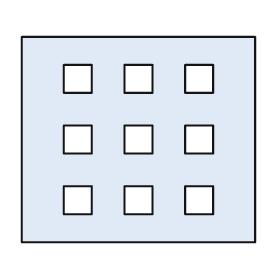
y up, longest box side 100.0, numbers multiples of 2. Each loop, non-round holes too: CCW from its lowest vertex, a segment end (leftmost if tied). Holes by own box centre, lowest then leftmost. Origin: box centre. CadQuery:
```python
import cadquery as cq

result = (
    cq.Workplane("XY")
    .moveTo(-50.0, -44.0)
    .lineTo(50.0, -44.0)
    .lineTo(50.0, 44.0)
    .lineTo(-50.0, 44.0)
    .close()
    .moveTo(-32.0, -32.0)
    .lineTo(-20.0, -32.0)
    .lineTo(-20.0, -20.0)
    .lineTo(-32.0, -20.0)
    .close()
    .moveTo(-6.0, -32.0)
    .lineTo(6.0, -32.0)
    .lineTo(6.0, -20.0)
    .lineTo(-6.0, -20.0)
    .close()
    .moveTo(20.0, -32.0)
    .lineTo(32.0, -32.0)
    .lineTo(32.0, -20.0)
    .lineTo(20.0, -20.0)
    .close()
    .moveTo(-32.0, -6.0)
    .lineTo(-20.0, -6.0)
    .lineTo(-20.0, 6.0)
    .lineTo(-32.0, 6.0)
    .close()
    .moveTo(-6.0, -6.0)
    .lineTo(6.0, -6.0)
    .lineTo(6.0, 6.0)
    .lineTo(-6.0, 6.0)
    .close()
    .moveTo(20.0, -6.0)
    .lineTo(32.0, -6.0)
    .lineTo(32.0, 6.0)
    .lineTo(20.0, 6.0)
    .close()
    .moveTo(-32.0, 20.0)
    .lineTo(-20.0, 20.0)
    .lineTo(-20.0, 32.0)
    .lineTo(-32.0, 32.0)
    .close()
    .moveTo(-6.0, 20.0)
    .lineTo(6.0, 20.0)
    .lineTo(6.0, 32.0)
    .lineTo(-6.0, 32.0)
    .close()
    .moveTo(20.0, 20.0)
    .lineTo(32.0, 20.0)
    .lineTo(32.0, 32.0)
    .lineTo(20.0, 32.0)
    .close()
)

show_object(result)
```